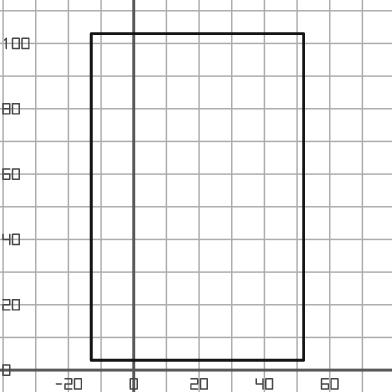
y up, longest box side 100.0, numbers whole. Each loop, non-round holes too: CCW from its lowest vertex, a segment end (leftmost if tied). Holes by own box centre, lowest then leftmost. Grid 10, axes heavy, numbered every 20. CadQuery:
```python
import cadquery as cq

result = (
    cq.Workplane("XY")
    .moveTo(-13.0, 3.0)
    .lineTo(52.0, 3.0)
    .lineTo(52.0, 103.0)
    .lineTo(-13.0, 103.0)
    .close()
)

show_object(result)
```